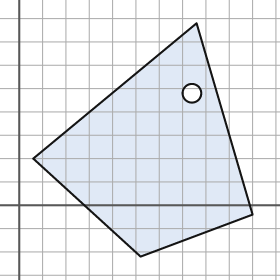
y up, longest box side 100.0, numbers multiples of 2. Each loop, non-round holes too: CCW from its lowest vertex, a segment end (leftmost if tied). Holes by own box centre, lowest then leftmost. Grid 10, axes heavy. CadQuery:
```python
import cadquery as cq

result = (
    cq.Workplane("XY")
    .moveTo(52.0, -22.0)
    .lineTo(100.0, -4.0)
    .lineTo(76.0, 78.0)
    .lineTo(6.0, 20.0)
    .close()
    .moveTo(74.0, 48.0)
    .circle(4.0)
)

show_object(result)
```